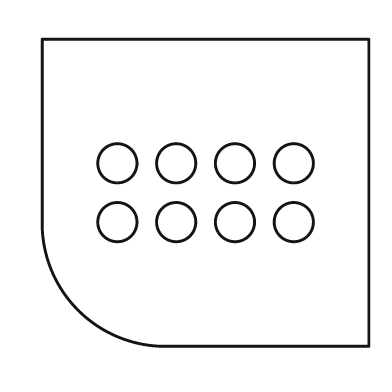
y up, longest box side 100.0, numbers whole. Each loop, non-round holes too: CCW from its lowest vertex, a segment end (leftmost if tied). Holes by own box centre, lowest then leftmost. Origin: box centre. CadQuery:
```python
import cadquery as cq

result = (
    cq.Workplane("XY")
    .moveTo(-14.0, -47.0)
    .lineTo(50.0, -47.0)
    .lineTo(50.0, 47.0)
    .lineTo(-50.0, 47.0)
    .lineTo(-50.0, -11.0)
    .threePointArc((-39.0, -36.0), (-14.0, -47.0))
    .close()
    .moveTo(-27.0, -9.0)
    .circle(6.0)
    .moveTo(-9.0, -9.0)
    .circle(6.0)
    .moveTo(9.0, -9.0)
    .circle(6.0)
    .moveTo(27.0, -9.0)
    .circle(6.0)
    .moveTo(-27.0, 9.0)
    .circle(6.0)
    .moveTo(-9.0, 9.0)
    .circle(6.0)
    .moveTo(9.0, 9.0)
    .circle(6.0)
    .moveTo(27.0, 9.0)
    .circle(6.0)
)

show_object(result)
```